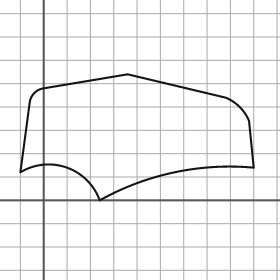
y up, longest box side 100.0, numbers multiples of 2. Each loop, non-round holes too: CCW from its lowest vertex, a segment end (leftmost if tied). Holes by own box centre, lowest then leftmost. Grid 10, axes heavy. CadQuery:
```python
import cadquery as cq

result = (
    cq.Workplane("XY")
    .moveTo(24.0, 0.0)
    .threePointArc((56.0, 12.0), (90.0, 14.0))
    .lineTo(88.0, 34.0)
    .threePointArc((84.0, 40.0), (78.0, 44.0))
    .lineTo(36.0, 54.0)
    .lineTo(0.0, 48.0)
    .threePointArc((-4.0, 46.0), (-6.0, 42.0))
    .lineTo(-10.0, 12.0)
    .threePointArc((10.0, 14.0), (24.0, 0.0))
    .close()
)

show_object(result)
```